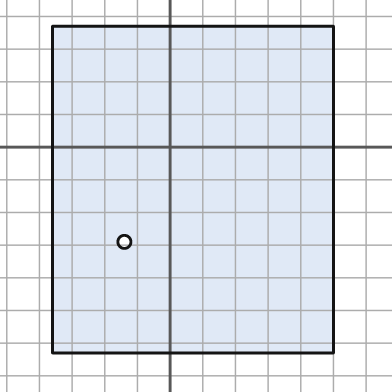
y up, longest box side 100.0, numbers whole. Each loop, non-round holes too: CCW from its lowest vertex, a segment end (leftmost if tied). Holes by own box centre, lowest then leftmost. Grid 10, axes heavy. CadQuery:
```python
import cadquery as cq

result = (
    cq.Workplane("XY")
    .moveTo(-36.0, -63.0)
    .lineTo(50.0, -63.0)
    .lineTo(50.0, 37.0)
    .lineTo(-36.0, 37.0)
    .close()
    .moveTo(-14.0, -29.0)
    .circle(2.0)
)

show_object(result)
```